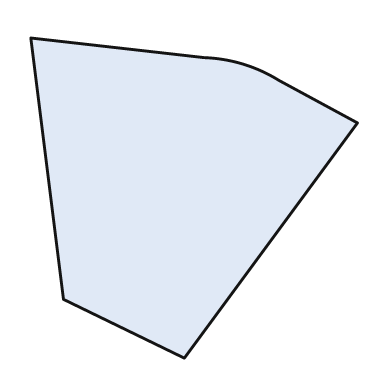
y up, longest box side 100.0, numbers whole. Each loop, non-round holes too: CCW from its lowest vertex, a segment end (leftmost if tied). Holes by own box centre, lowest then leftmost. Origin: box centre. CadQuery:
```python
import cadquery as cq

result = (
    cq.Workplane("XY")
    .moveTo(-3.0, -49.0)
    .lineTo(50.0, 23.0)
    .lineTo(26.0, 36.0)
    .threePointArc((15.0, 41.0), (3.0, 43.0))
    .lineTo(-50.0, 49.0)
    .lineTo(-40.0, -31.0)
    .close()
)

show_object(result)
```